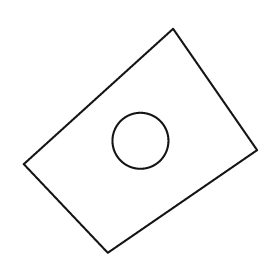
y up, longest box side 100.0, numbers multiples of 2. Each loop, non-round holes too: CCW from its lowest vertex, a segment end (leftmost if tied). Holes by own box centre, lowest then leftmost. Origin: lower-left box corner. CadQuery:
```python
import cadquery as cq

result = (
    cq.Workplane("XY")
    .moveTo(36.0, 0.0)
    .lineTo(100.0, 44.0)
    .lineTo(64.0, 96.0)
    .lineTo(0.0, 38.0)
    .close()
    .moveTo(50.0, 48.0)
    .circle(12.0)
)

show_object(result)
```